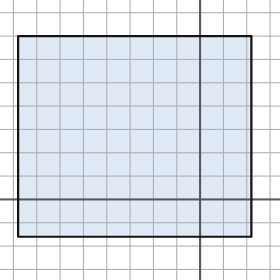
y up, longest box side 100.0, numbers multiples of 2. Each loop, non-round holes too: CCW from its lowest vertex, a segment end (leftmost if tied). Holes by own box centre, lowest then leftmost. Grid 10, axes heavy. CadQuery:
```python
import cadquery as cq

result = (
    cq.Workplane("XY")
    .moveTo(-78.0, -16.0)
    .lineTo(22.0, -16.0)
    .lineTo(22.0, 70.0)
    .lineTo(-78.0, 70.0)
    .close()
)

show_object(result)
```